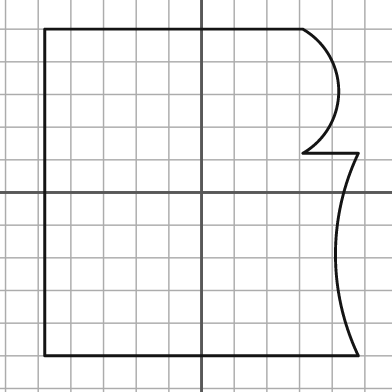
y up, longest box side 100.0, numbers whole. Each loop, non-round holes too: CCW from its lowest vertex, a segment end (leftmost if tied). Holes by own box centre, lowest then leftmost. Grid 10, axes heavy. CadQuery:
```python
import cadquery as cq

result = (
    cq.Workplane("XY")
    .moveTo(-48.0, -50.0)
    .lineTo(48.0, -50.0)
    .threePointArc((41.0, -19.0), (48.0, 12.0))
    .lineTo(31.0, 12.0)
    .threePointArc((42.0, 31.0), (31.0, 50.0))
    .lineTo(-48.0, 50.0)
    .close()
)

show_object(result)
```